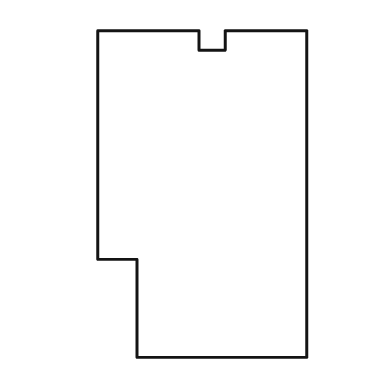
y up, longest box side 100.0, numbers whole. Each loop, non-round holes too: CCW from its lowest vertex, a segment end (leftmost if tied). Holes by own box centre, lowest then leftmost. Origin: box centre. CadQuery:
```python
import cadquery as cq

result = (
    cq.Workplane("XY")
    .moveTo(-20.0, -50.0)
    .lineTo(32.0, -50.0)
    .lineTo(32.0, 50.0)
    .lineTo(7.0, 50.0)
    .lineTo(7.0, 44.0)
    .lineTo(-1.0, 44.0)
    .lineTo(-1.0, 50.0)
    .lineTo(-32.0, 50.0)
    .lineTo(-32.0, -20.0)
    .lineTo(-20.0, -20.0)
    .close()
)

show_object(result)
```